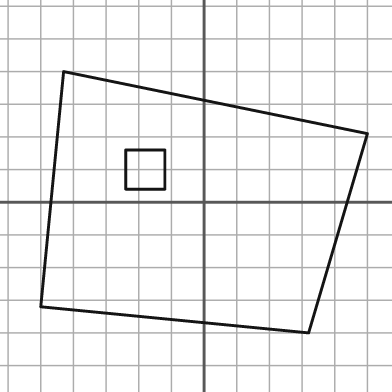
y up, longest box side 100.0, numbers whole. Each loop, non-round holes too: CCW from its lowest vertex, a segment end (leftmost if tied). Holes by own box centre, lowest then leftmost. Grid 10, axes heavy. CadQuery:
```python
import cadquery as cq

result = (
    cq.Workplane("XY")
    .moveTo(32.0, -40.0)
    .lineTo(50.0, 21.0)
    .lineTo(-43.0, 40.0)
    .lineTo(-50.0, -32.0)
    .close()
    .moveTo(-24.0, 4.0)
    .lineTo(-12.0, 4.0)
    .lineTo(-12.0, 16.0)
    .lineTo(-24.0, 16.0)
    .close()
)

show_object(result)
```